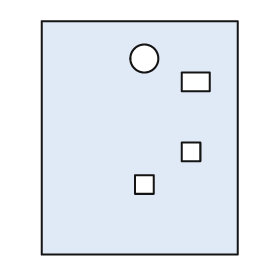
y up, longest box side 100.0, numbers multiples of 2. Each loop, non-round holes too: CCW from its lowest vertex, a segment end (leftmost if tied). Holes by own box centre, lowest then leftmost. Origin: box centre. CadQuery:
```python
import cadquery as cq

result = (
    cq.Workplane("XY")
    .moveTo(-42.0, -50.0)
    .lineTo(42.0, -50.0)
    .lineTo(42.0, 50.0)
    .lineTo(-42.0, 50.0)
    .close()
    .moveTo(-2.0, -24.0)
    .lineTo(6.0, -24.0)
    .lineTo(6.0, -16.0)
    .lineTo(-2.0, -16.0)
    .close()
    .moveTo(18.0, -10.0)
    .lineTo(26.0, -10.0)
    .lineTo(26.0, -2.0)
    .lineTo(18.0, -2.0)
    .close()
    .moveTo(18.0, 20.0)
    .lineTo(30.0, 20.0)
    .lineTo(30.0, 28.0)
    .lineTo(18.0, 28.0)
    .close()
    .moveTo(2.0, 34.0)
    .circle(6.0)
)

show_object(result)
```